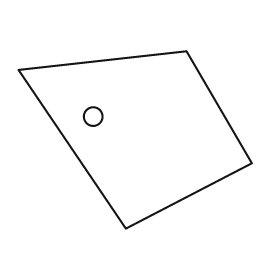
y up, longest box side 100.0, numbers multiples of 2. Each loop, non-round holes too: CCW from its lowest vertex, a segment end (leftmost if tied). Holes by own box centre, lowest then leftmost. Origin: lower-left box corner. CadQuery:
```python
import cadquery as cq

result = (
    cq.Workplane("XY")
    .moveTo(46.0, 0.0)
    .lineTo(100.0, 28.0)
    .lineTo(72.0, 76.0)
    .lineTo(0.0, 68.0)
    .close()
    .moveTo(32.0, 48.0)
    .circle(4.0)
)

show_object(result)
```